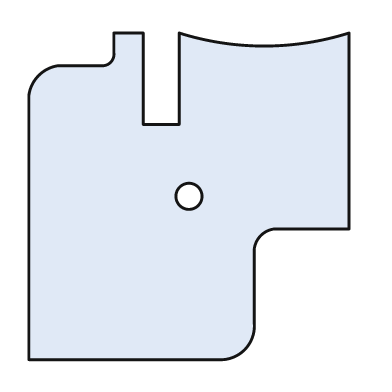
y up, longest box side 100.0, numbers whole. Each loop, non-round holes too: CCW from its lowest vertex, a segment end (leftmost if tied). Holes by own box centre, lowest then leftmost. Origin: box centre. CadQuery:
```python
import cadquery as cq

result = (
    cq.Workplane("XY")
    .moveTo(-49.0, -50.0)
    .lineTo(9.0, -50.0)
    .threePointArc((17.0, -47.0), (20.0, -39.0))
    .lineTo(20.0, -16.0)
    .threePointArc((22.0, -12.0), (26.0, -10.0))
    .lineTo(49.0, -10.0)
    .lineTo(49.0, 50.0)
    .threePointArc((23.0, 46.0), (-3.0, 50.0))
    .lineTo(-3.0, 22.0)
    .lineTo(-14.0, 22.0)
    .lineTo(-14.0, 50.0)
    .lineTo(-23.0, 50.0)
    .lineTo(-23.0, 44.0)
    .threePointArc((-24.0, 41.0), (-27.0, 40.0))
    .lineTo(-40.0, 40.0)
    .threePointArc((-46.0, 37.0), (-49.0, 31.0))
    .close()
    .moveTo(0.0, 0.0)
    .circle(4.0)
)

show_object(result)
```